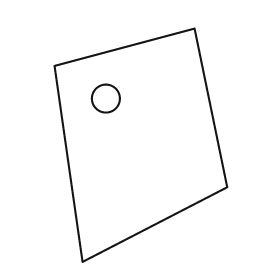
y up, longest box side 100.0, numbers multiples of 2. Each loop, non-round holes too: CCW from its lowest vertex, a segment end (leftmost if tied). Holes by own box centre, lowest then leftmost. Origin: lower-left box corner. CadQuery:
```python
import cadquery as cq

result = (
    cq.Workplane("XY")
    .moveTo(12.0, 0.0)
    .lineTo(74.0, 32.0)
    .lineTo(60.0, 100.0)
    .lineTo(0.0, 84.0)
    .close()
    .moveTo(22.0, 70.0)
    .circle(6.0)
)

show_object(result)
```